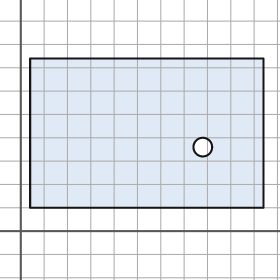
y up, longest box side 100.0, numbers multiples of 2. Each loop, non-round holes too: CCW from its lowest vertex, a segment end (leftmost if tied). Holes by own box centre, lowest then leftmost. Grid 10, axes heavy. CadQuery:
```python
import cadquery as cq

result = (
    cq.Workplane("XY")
    .moveTo(4.0, 10.0)
    .lineTo(104.0, 10.0)
    .lineTo(104.0, 74.0)
    .lineTo(4.0, 74.0)
    .close()
    .moveTo(78.0, 36.0)
    .circle(4.0)
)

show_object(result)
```